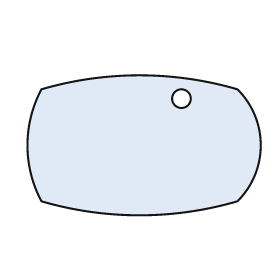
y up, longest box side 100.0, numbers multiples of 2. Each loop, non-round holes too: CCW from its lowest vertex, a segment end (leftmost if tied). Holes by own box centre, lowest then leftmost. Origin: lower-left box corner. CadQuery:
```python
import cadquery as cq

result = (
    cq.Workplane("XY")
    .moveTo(6.0, 6.0)
    .threePointArc((48.0, 0.0), (90.0, 6.0))
    .threePointArc((100.0, 30.0), (90.0, 54.0))
    .threePointArc((48.0, 60.0), (6.0, 54.0))
    .threePointArc((0.0, 30.0), (6.0, 6.0))
    .close()
    .moveTo(66.0, 50.0)
    .circle(4.0)
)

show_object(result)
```